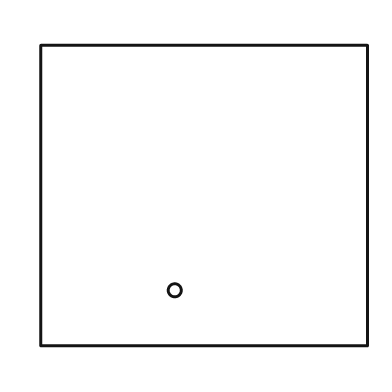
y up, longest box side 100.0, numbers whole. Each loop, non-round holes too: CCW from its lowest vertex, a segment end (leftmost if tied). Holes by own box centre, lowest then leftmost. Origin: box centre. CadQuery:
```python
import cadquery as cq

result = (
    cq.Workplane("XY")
    .moveTo(-50.0, -46.0)
    .lineTo(50.0, -46.0)
    .lineTo(50.0, 46.0)
    .lineTo(-50.0, 46.0)
    .close()
    .moveTo(-9.0, -29.0)
    .circle(2.0)
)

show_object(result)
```